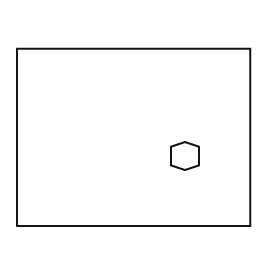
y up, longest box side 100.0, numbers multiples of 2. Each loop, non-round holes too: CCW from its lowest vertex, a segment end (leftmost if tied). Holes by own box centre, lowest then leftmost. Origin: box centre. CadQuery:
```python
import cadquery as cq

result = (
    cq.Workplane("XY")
    .moveTo(-50.0, -38.0)
    .lineTo(50.0, -38.0)
    .lineTo(50.0, 38.0)
    .lineTo(-50.0, 38.0)
    .close()
    .moveTo(22.0, -14.0)
    .lineTo(28.0, -12.0)
    .lineTo(28.0, -4.0)
    .lineTo(22.0, -2.0)
    .lineTo(16.0, -4.0)
    .lineTo(16.0, -12.0)
    .close()
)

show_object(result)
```